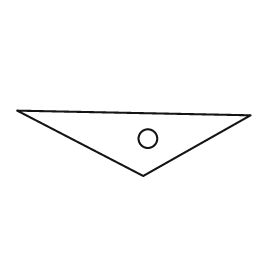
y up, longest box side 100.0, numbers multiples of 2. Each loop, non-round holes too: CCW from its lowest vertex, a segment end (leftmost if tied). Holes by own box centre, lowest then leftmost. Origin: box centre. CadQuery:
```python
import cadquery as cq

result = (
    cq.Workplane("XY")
    .moveTo(4.0, -14.0)
    .lineTo(50.0, 12.0)
    .lineTo(-50.0, 14.0)
    .close()
    .moveTo(6.0, 2.0)
    .circle(4.0)
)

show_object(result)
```